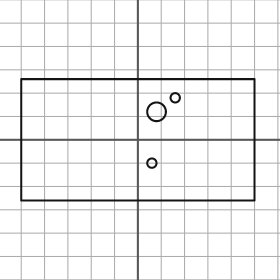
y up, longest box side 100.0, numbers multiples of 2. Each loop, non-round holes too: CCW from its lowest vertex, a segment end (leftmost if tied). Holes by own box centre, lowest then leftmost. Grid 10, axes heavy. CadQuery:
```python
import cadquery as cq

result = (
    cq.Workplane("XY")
    .moveTo(-50.0, -26.0)
    .lineTo(50.0, -26.0)
    .lineTo(50.0, 26.0)
    .lineTo(-50.0, 26.0)
    .close()
    .moveTo(6.0, -10.0)
    .circle(2.0)
    .moveTo(8.0, 12.0)
    .circle(4.0)
    .moveTo(16.0, 18.0)
    .circle(2.0)
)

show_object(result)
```